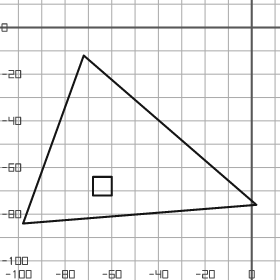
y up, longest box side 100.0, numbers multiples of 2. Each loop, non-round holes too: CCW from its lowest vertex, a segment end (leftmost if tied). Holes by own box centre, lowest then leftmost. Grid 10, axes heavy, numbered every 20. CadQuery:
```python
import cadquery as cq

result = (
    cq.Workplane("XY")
    .moveTo(-98.0, -84.0)
    .lineTo(2.0, -76.0)
    .lineTo(-72.0, -12.0)
    .close()
    .moveTo(-68.0, -72.0)
    .lineTo(-60.0, -72.0)
    .lineTo(-60.0, -64.0)
    .lineTo(-68.0, -64.0)
    .close()
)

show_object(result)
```